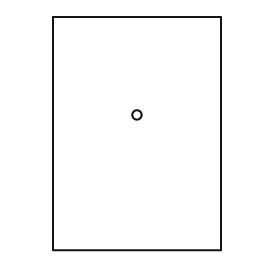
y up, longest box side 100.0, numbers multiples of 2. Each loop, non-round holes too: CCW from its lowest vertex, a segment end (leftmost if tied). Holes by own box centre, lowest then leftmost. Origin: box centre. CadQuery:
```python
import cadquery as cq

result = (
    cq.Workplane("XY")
    .moveTo(-36.0, -50.0)
    .lineTo(36.0, -50.0)
    .lineTo(36.0, 50.0)
    .lineTo(-36.0, 50.0)
    .close()
    .moveTo(0.0, 8.0)
    .circle(2.0)
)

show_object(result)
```